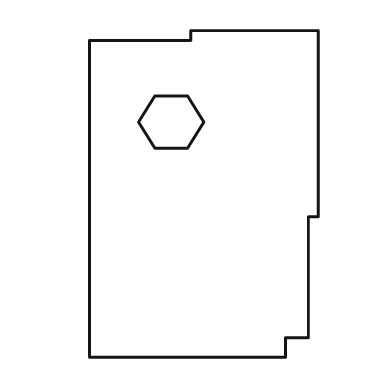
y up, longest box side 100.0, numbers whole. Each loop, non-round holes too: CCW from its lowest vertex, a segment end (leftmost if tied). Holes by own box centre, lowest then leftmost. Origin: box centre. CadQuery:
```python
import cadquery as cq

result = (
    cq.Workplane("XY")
    .moveTo(-35.0, -50.0)
    .lineTo(25.0, -50.0)
    .lineTo(25.0, -44.0)
    .lineTo(32.0, -44.0)
    .lineTo(32.0, -7.0)
    .lineTo(35.0, -7.0)
    .lineTo(35.0, 50.0)
    .lineTo(-4.0, 50.0)
    .lineTo(-4.0, 47.0)
    .lineTo(-35.0, 47.0)
    .close()
    .moveTo(-15.0, 14.0)
    .lineTo(-5.0, 14.0)
    .lineTo(0.0, 22.0)
    .lineTo(-5.0, 30.0)
    .lineTo(-15.0, 30.0)
    .lineTo(-20.0, 22.0)
    .close()
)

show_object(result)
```